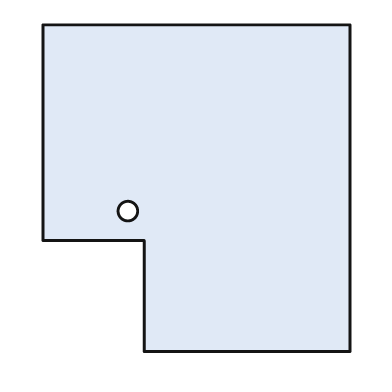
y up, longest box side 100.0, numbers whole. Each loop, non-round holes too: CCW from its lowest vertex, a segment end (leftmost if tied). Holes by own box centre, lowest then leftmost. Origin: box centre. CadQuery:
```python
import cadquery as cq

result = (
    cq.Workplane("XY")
    .moveTo(-16.0, -50.0)
    .lineTo(47.0, -50.0)
    .lineTo(47.0, 50.0)
    .lineTo(-47.0, 50.0)
    .lineTo(-47.0, -16.0)
    .lineTo(-16.0, -16.0)
    .close()
    .moveTo(-21.0, -7.0)
    .circle(3.0)
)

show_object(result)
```